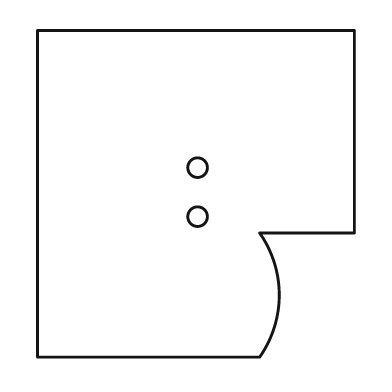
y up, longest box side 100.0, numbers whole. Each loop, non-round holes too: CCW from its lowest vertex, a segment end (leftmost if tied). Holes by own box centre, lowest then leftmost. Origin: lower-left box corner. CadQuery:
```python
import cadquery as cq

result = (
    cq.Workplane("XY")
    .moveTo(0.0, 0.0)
    .lineTo(68.0, 0.0)
    .threePointArc((74.0, 19.0), (68.0, 38.0))
    .lineTo(97.0, 38.0)
    .lineTo(97.0, 100.0)
    .lineTo(0.0, 100.0)
    .close()
    .moveTo(49.0, 43.0)
    .circle(3.0)
    .moveTo(49.0, 58.0)
    .circle(3.0)
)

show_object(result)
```